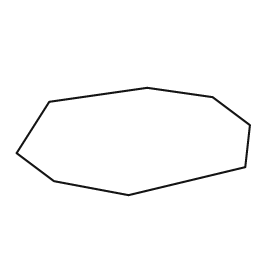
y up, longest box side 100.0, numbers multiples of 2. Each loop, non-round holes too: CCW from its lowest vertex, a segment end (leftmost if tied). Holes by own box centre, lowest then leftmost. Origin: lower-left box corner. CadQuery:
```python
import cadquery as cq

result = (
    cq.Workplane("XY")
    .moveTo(48.0, 0.0)
    .lineTo(98.0, 12.0)
    .lineTo(100.0, 30.0)
    .lineTo(84.0, 42.0)
    .lineTo(56.0, 46.0)
    .lineTo(14.0, 40.0)
    .lineTo(0.0, 18.0)
    .lineTo(16.0, 6.0)
    .close()
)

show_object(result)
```